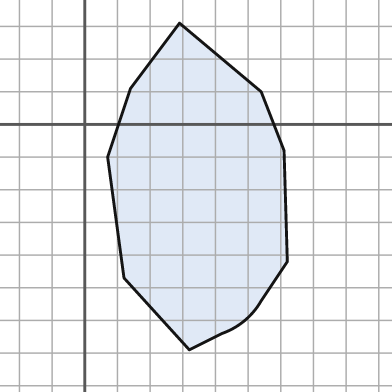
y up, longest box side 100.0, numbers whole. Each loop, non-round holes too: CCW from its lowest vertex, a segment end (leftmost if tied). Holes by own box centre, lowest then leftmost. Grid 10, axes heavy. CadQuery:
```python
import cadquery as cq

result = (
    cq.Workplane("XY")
    .moveTo(32.0, -69.0)
    .lineTo(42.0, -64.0)
    .threePointArc((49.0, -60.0), (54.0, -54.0))
    .lineTo(62.0, -42.0)
    .lineTo(61.0, -8.0)
    .lineTo(54.0, 10.0)
    .lineTo(29.0, 31.0)
    .lineTo(14.0, 11.0)
    .lineTo(7.0, -10.0)
    .lineTo(12.0, -47.0)
    .close()
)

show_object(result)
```